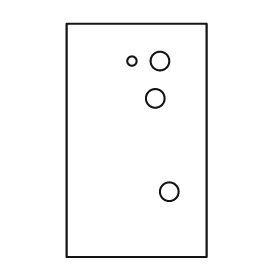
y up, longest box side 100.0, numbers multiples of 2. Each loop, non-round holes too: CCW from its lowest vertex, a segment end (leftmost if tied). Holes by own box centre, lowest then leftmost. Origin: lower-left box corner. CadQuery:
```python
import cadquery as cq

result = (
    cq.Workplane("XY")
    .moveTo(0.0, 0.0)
    .lineTo(60.0, 0.0)
    .lineTo(60.0, 100.0)
    .lineTo(0.0, 100.0)
    .close()
    .moveTo(44.0, 28.0)
    .circle(4.0)
    .moveTo(38.0, 68.0)
    .circle(4.0)
    .moveTo(28.0, 84.0)
    .circle(2.0)
    .moveTo(40.0, 84.0)
    .circle(4.0)
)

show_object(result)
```